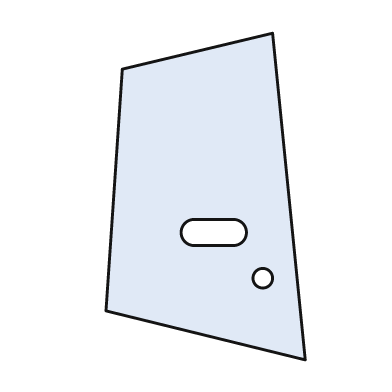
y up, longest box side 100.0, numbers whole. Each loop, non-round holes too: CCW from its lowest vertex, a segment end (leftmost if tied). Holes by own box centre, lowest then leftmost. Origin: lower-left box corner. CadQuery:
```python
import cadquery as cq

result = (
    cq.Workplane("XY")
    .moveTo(61.0, 0.0)
    .lineTo(51.0, 100.0)
    .lineTo(5.0, 89.0)
    .lineTo(0.0, 15.0)
    .close()
    .moveTo(48.0, 25.0)
    .circle(3.0)
    .moveTo(27.0, 35.0)
    .lineTo(39.0, 35.0)
    .threePointArc((43.0, 39.0), (39.0, 43.0))
    .lineTo(27.0, 43.0)
    .threePointArc((23.0, 39.0), (27.0, 35.0))
    .close()
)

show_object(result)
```